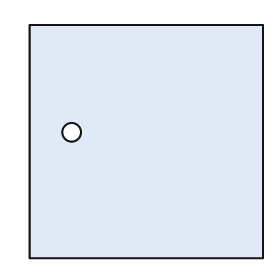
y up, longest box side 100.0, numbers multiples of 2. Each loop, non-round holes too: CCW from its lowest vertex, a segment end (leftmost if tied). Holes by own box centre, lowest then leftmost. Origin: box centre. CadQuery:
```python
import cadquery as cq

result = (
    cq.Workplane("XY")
    .moveTo(-50.0, -50.0)
    .lineTo(50.0, -50.0)
    .lineTo(50.0, 50.0)
    .lineTo(-50.0, 50.0)
    .close()
    .moveTo(-32.0, 4.0)
    .circle(4.0)
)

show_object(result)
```